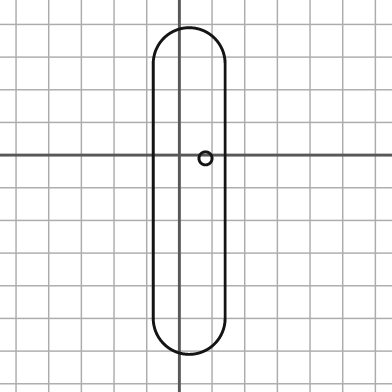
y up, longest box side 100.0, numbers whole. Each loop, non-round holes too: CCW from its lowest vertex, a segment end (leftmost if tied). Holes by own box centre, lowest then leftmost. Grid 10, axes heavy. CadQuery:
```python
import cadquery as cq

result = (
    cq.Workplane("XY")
    .moveTo(-8.0, -50.0)
    .threePointArc((3.0, -61.0), (14.0, -50.0))
    .lineTo(14.0, 28.0)
    .threePointArc((3.0, 39.0), (-8.0, 28.0))
    .close()
    .moveTo(8.0, -1.0)
    .circle(2.0)
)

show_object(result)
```